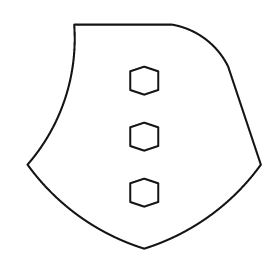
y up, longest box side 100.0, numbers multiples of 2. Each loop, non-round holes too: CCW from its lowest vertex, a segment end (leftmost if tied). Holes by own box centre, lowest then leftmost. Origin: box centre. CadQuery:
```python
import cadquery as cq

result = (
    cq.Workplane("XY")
    .moveTo(0.0, -48.0)
    .threePointArc((28.0, -34.0), (50.0, -12.0))
    .lineTo(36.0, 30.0)
    .threePointArc((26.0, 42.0), (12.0, 48.0))
    .lineTo(-30.0, 48.0)
    .threePointArc((-34.0, 16.0), (-50.0, -12.0))
    .threePointArc((-28.0, -34.0), (0.0, -48.0))
    .close()
    .moveTo(0.0, -30.0)
    .lineTo(6.0, -28.0)
    .lineTo(6.0, -20.0)
    .lineTo(0.0, -18.0)
    .lineTo(-6.0, -20.0)
    .lineTo(-6.0, -28.0)
    .close()
    .moveTo(0.0, -6.0)
    .lineTo(6.0, -4.0)
    .lineTo(6.0, 4.0)
    .lineTo(0.0, 6.0)
    .lineTo(-6.0, 4.0)
    .lineTo(-6.0, -4.0)
    .close()
    .moveTo(0.0, 18.0)
    .lineTo(6.0, 20.0)
    .lineTo(6.0, 28.0)
    .lineTo(0.0, 30.0)
    .lineTo(-6.0, 28.0)
    .lineTo(-6.0, 20.0)
    .close()
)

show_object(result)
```